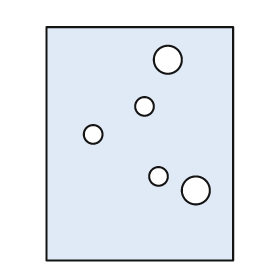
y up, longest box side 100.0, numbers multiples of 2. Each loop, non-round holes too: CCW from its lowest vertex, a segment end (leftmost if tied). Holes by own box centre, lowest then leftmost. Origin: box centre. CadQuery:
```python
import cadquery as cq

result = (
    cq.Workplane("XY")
    .moveTo(-40.0, -50.0)
    .lineTo(40.0, -50.0)
    .lineTo(40.0, 50.0)
    .lineTo(-40.0, 50.0)
    .close()
    .moveTo(24.0, -20.0)
    .circle(6.0)
    .moveTo(8.0, -14.0)
    .circle(4.0)
    .moveTo(-20.0, 4.0)
    .circle(4.0)
    .moveTo(2.0, 16.0)
    .circle(4.0)
    .moveTo(12.0, 36.0)
    .circle(6.0)
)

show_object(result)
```